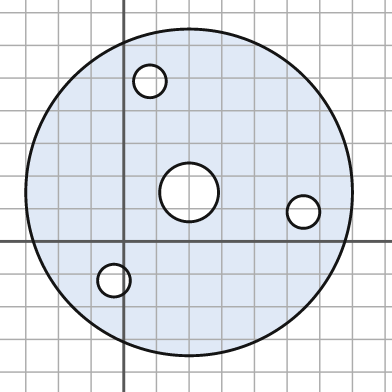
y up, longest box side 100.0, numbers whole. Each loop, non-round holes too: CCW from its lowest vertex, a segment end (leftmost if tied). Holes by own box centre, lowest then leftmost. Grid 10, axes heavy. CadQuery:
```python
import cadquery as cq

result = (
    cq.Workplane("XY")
    .moveTo(20.0, 15.0)
    .circle(50.0)
    .moveTo(-3.0, -12.0)
    .circle(5.0)
    .moveTo(55.0, 9.0)
    .circle(5.0)
    .moveTo(20.0, 15.0)
    .circle(9.0)
    .moveTo(8.0, 49.0)
    .circle(5.0)
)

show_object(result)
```